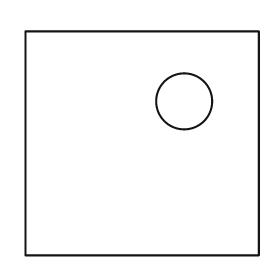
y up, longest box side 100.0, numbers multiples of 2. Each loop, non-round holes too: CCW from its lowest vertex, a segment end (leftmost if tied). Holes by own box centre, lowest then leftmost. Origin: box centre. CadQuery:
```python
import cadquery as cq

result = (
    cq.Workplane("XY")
    .moveTo(-50.0, -48.0)
    .lineTo(50.0, -48.0)
    .lineTo(50.0, 48.0)
    .lineTo(-50.0, 48.0)
    .close()
    .moveTo(18.0, 18.0)
    .circle(12.0)
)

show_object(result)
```